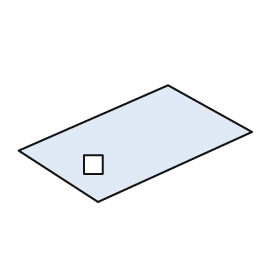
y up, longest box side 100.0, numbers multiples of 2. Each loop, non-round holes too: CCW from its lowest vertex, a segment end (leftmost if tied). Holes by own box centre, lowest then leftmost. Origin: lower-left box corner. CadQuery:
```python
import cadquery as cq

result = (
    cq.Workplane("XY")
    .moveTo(34.0, 0.0)
    .lineTo(100.0, 30.0)
    .lineTo(64.0, 50.0)
    .lineTo(0.0, 22.0)
    .close()
    .moveTo(28.0, 12.0)
    .lineTo(36.0, 12.0)
    .lineTo(36.0, 20.0)
    .lineTo(28.0, 20.0)
    .close()
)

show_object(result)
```